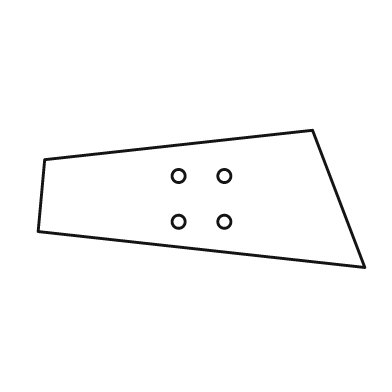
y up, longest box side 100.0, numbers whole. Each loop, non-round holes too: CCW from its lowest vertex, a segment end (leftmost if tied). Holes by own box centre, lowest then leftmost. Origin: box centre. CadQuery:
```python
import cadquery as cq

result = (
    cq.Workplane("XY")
    .moveTo(50.0, -21.0)
    .lineTo(34.0, 21.0)
    .lineTo(-48.0, 12.0)
    .lineTo(-50.0, -10.0)
    .close()
    .moveTo(-7.0, -7.0)
    .circle(2.0)
    .moveTo(7.0, -7.0)
    .circle(2.0)
    .moveTo(-7.0, 7.0)
    .circle(2.0)
    .moveTo(7.0, 7.0)
    .circle(2.0)
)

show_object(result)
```